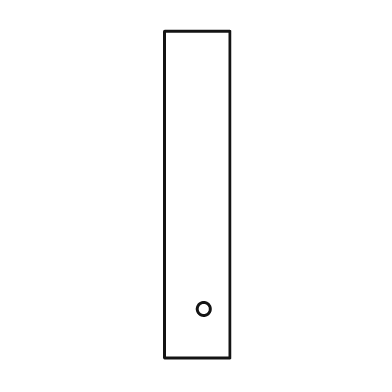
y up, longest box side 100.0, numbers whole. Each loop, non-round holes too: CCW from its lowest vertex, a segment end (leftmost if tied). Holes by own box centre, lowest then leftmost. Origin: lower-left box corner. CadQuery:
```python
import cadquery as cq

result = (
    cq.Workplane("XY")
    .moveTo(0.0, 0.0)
    .lineTo(20.0, 0.0)
    .lineTo(20.0, 100.0)
    .lineTo(0.0, 100.0)
    .close()
    .moveTo(12.0, 15.0)
    .circle(2.0)
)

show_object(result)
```